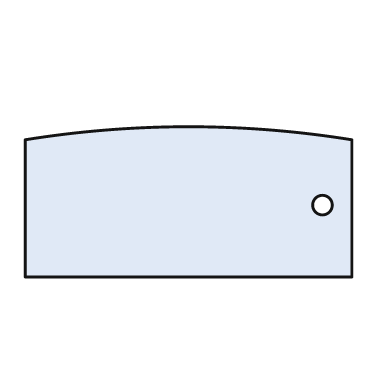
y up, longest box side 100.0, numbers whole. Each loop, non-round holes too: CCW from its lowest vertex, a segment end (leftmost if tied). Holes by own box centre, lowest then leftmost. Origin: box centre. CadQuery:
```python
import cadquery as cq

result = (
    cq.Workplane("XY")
    .moveTo(-50.0, -23.0)
    .lineTo(50.0, -23.0)
    .lineTo(50.0, 19.0)
    .threePointArc((0.0, 23.0), (-50.0, 19.0))
    .close()
    .moveTo(41.0, -1.0)
    .circle(3.0)
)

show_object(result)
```